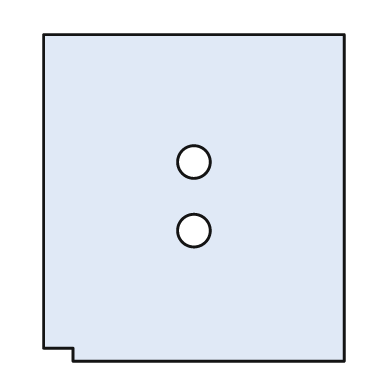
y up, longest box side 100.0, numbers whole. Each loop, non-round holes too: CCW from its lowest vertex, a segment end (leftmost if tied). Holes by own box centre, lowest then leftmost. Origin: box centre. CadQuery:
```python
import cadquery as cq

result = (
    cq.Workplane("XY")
    .moveTo(-37.0, -50.0)
    .lineTo(46.0, -50.0)
    .lineTo(46.0, 50.0)
    .lineTo(-46.0, 50.0)
    .lineTo(-46.0, -46.0)
    .lineTo(-37.0, -46.0)
    .close()
    .moveTo(0.0, -10.0)
    .circle(5.0)
    .moveTo(0.0, 11.0)
    .circle(5.0)
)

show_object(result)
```